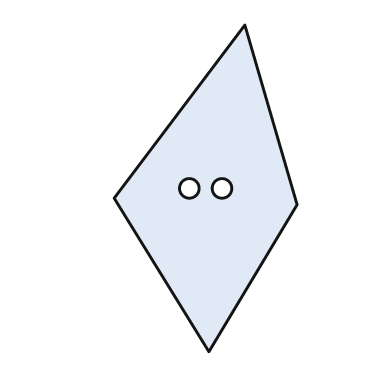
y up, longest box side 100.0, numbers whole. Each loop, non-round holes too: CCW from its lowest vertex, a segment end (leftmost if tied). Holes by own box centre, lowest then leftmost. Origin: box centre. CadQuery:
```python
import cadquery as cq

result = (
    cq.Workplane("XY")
    .moveTo(1.0, -50.0)
    .lineTo(28.0, -5.0)
    .lineTo(12.0, 50.0)
    .lineTo(-28.0, -3.0)
    .close()
    .moveTo(-5.0, 0.0)
    .circle(3.0)
    .moveTo(5.0, 0.0)
    .circle(3.0)
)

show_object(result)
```